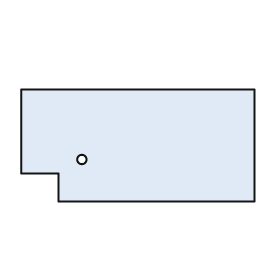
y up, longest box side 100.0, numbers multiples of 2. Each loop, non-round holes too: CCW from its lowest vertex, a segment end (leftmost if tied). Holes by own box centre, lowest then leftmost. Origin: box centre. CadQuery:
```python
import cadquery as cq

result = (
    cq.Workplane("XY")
    .moveTo(-34.0, -24.0)
    .lineTo(50.0, -24.0)
    .lineTo(50.0, 24.0)
    .lineTo(-50.0, 24.0)
    .lineTo(-50.0, -12.0)
    .lineTo(-34.0, -12.0)
    .close()
    .moveTo(-24.0, -6.0)
    .circle(2.0)
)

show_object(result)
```